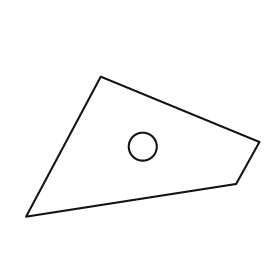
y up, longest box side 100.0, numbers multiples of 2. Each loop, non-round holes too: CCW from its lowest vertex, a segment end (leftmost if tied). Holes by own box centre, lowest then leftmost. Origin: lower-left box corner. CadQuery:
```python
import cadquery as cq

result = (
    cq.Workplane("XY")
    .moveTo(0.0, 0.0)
    .lineTo(90.0, 14.0)
    .lineTo(100.0, 32.0)
    .lineTo(32.0, 60.0)
    .close()
    .moveTo(50.0, 30.0)
    .circle(6.0)
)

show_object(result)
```